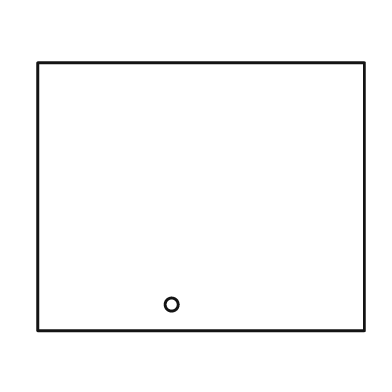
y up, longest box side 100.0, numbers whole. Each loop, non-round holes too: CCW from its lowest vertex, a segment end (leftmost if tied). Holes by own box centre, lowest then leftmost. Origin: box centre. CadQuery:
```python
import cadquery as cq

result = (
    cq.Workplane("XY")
    .moveTo(-50.0, -41.0)
    .lineTo(50.0, -41.0)
    .lineTo(50.0, 41.0)
    .lineTo(-50.0, 41.0)
    .close()
    .moveTo(-9.0, -33.0)
    .circle(2.0)
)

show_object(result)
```